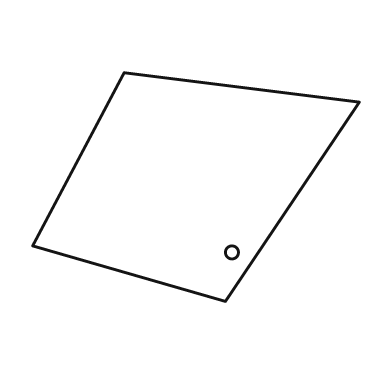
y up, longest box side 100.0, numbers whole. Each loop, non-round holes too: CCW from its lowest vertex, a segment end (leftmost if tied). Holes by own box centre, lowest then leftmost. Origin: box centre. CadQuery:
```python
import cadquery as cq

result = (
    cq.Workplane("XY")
    .moveTo(9.0, -35.0)
    .lineTo(50.0, 26.0)
    .lineTo(-22.0, 35.0)
    .lineTo(-50.0, -18.0)
    .close()
    .moveTo(11.0, -20.0)
    .circle(2.0)
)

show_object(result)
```